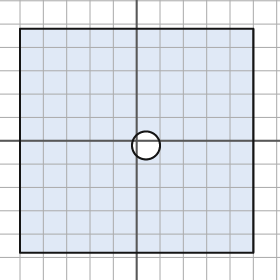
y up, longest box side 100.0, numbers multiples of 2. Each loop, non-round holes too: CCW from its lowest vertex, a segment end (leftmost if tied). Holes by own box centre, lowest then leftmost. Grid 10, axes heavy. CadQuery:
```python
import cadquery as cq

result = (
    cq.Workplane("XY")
    .moveTo(-50.0, -48.0)
    .lineTo(50.0, -48.0)
    .lineTo(50.0, 48.0)
    .lineTo(-50.0, 48.0)
    .close()
    .moveTo(4.0, -2.0)
    .circle(6.0)
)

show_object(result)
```